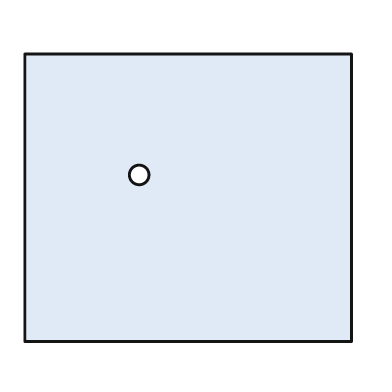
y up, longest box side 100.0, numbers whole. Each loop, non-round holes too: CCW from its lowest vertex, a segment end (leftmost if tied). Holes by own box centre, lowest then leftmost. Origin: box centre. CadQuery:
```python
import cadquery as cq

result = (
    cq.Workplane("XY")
    .moveTo(-50.0, -44.0)
    .lineTo(50.0, -44.0)
    .lineTo(50.0, 44.0)
    .lineTo(-50.0, 44.0)
    .close()
    .moveTo(-15.0, 7.0)
    .circle(3.0)
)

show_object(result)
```